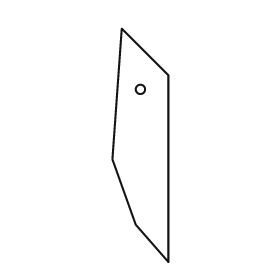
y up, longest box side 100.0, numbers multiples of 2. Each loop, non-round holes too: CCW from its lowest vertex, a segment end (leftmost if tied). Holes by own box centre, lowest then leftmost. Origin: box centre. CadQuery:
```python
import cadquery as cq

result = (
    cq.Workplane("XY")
    .moveTo(12.0, -50.0)
    .lineTo(12.0, 30.0)
    .lineTo(-8.0, 50.0)
    .lineTo(-12.0, -6.0)
    .lineTo(-2.0, -34.0)
    .close()
    .moveTo(0.0, 24.0)
    .circle(2.0)
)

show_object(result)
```